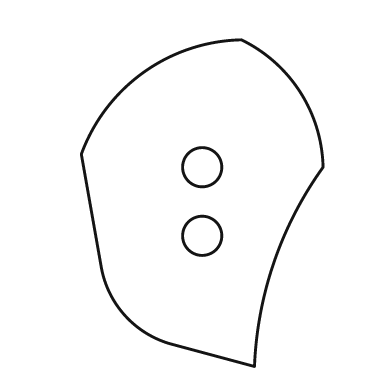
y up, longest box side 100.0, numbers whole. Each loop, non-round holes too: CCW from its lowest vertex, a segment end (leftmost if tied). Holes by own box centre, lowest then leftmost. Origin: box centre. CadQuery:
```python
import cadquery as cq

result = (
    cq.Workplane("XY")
    .moveTo(16.0, -50.0)
    .threePointArc((22.0, -18.0), (37.0, 11.0))
    .threePointArc((30.0, 34.0), (12.0, 50.0))
    .threePointArc((-18.0, 40.0), (-37.0, 15.0))
    .lineTo(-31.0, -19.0)
    .threePointArc((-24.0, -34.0), (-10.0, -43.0))
    .close()
    .moveTo(0.0, -10.0)
    .circle(6.0)
    .moveTo(0.0, 11.0)
    .circle(6.0)
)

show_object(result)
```